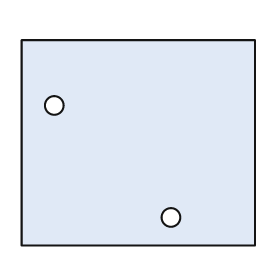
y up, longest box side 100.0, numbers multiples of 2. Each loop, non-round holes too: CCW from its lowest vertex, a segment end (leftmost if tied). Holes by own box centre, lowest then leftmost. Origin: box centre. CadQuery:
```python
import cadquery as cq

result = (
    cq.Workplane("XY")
    .moveTo(-50.0, -44.0)
    .lineTo(50.0, -44.0)
    .lineTo(50.0, 44.0)
    .lineTo(-50.0, 44.0)
    .close()
    .moveTo(14.0, -32.0)
    .circle(4.0)
    .moveTo(-36.0, 16.0)
    .circle(4.0)
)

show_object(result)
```